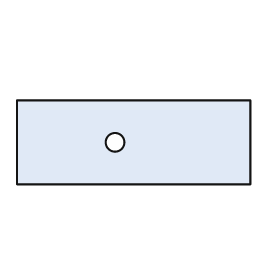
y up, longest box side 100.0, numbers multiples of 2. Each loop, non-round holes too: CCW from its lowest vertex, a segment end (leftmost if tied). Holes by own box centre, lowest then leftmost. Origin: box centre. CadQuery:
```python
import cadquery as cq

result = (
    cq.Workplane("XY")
    .moveTo(-50.0, -18.0)
    .lineTo(50.0, -18.0)
    .lineTo(50.0, 18.0)
    .lineTo(-50.0, 18.0)
    .close()
    .moveTo(-8.0, 0.0)
    .circle(4.0)
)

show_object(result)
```